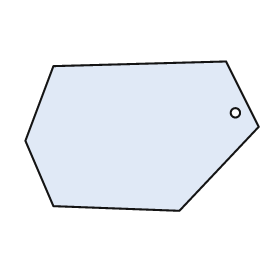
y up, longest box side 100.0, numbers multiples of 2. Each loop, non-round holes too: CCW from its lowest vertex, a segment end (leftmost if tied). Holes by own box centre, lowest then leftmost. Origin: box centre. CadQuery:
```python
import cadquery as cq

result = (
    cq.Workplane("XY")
    .moveTo(16.0, -32.0)
    .lineTo(50.0, 4.0)
    .lineTo(36.0, 32.0)
    .lineTo(-38.0, 30.0)
    .lineTo(-50.0, -2.0)
    .lineTo(-38.0, -30.0)
    .close()
    .moveTo(40.0, 10.0)
    .circle(2.0)
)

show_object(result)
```